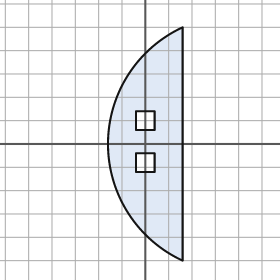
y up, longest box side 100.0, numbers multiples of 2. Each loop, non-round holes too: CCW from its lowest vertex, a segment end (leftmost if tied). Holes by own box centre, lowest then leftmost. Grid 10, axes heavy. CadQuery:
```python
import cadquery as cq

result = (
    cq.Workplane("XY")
    .moveTo(16.0, -50.0)
    .lineTo(16.0, 50.0)
    .threePointArc((-16.0, 0.0), (16.0, -50.0))
    .close()
    .moveTo(-4.0, -12.0)
    .lineTo(4.0, -12.0)
    .lineTo(4.0, -4.0)
    .lineTo(-4.0, -4.0)
    .close()
    .moveTo(-4.0, 6.0)
    .lineTo(4.0, 6.0)
    .lineTo(4.0, 14.0)
    .lineTo(-4.0, 14.0)
    .close()
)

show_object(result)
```